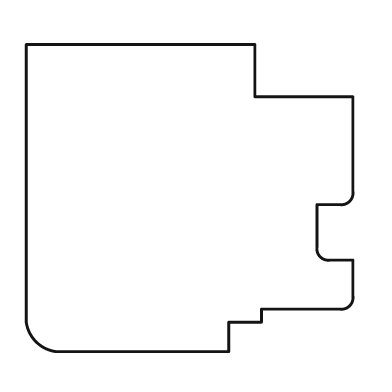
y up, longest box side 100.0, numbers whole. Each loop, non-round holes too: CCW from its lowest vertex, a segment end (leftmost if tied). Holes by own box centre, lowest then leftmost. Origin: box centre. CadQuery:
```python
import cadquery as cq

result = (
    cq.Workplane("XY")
    .moveTo(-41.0, -47.0)
    .lineTo(12.0, -47.0)
    .lineTo(12.0, -38.0)
    .lineTo(22.0, -38.0)
    .lineTo(22.0, -34.0)
    .lineTo(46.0, -34.0)
    .threePointArc((49.0, -33.0), (50.0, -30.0))
    .lineTo(50.0, -19.0)
    .lineTo(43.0, -19.0)
    .threePointArc((40.0, -18.0), (39.0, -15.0))
    .lineTo(39.0, -2.0)
    .lineTo(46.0, -2.0)
    .threePointArc((49.0, -1.0), (50.0, 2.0))
    .lineTo(50.0, 31.0)
    .lineTo(20.0, 31.0)
    .lineTo(20.0, 47.0)
    .lineTo(-50.0, 47.0)
    .lineTo(-50.0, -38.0)
    .threePointArc((-47.0, -44.0), (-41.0, -47.0))
    .close()
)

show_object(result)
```